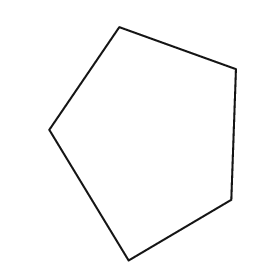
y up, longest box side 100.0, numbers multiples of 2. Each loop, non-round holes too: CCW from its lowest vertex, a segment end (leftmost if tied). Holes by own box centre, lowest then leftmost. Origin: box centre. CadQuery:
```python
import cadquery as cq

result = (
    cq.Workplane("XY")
    .moveTo(-6.0, -50.0)
    .lineTo(38.0, -24.0)
    .lineTo(40.0, 32.0)
    .lineTo(-10.0, 50.0)
    .lineTo(-40.0, 6.0)
    .close()
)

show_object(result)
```